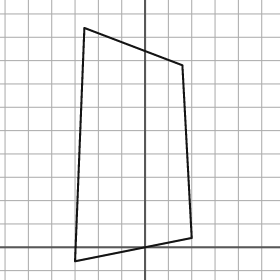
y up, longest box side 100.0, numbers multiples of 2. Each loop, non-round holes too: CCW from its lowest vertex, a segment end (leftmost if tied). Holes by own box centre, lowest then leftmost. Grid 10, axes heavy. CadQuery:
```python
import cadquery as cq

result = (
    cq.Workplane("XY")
    .moveTo(-30.0, -6.0)
    .lineTo(20.0, 4.0)
    .lineTo(16.0, 78.0)
    .lineTo(-26.0, 94.0)
    .close()
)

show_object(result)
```